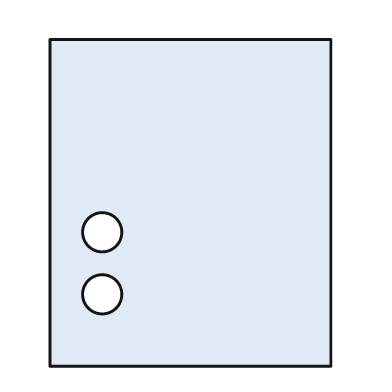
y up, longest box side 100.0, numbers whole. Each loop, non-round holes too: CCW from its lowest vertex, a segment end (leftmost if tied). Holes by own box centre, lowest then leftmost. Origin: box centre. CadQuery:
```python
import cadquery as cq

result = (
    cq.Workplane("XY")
    .moveTo(-43.0, -50.0)
    .lineTo(43.0, -50.0)
    .lineTo(43.0, 50.0)
    .lineTo(-43.0, 50.0)
    .close()
    .moveTo(-27.0, -28.0)
    .circle(6.0)
    .moveTo(-27.0, -9.0)
    .circle(6.0)
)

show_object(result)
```